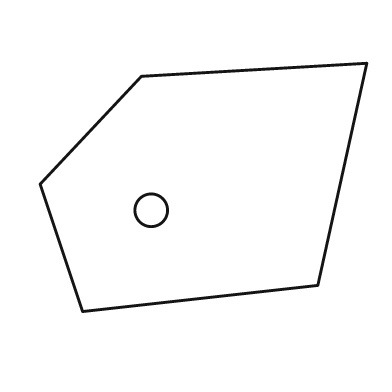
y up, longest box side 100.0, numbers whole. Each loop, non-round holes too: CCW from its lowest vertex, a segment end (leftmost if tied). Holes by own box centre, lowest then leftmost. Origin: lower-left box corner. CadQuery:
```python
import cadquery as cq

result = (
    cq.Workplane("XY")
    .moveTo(13.0, 0.0)
    .lineTo(85.0, 8.0)
    .lineTo(100.0, 76.0)
    .lineTo(31.0, 72.0)
    .lineTo(0.0, 39.0)
    .close()
    .moveTo(34.0, 31.0)
    .circle(5.0)
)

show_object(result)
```